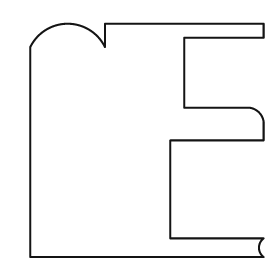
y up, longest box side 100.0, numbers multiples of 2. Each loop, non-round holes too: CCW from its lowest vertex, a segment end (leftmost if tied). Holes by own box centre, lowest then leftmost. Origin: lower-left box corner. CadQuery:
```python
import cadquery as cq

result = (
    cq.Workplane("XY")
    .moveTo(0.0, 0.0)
    .lineTo(100.0, 0.0)
    .threePointArc((98.0, 4.0), (100.0, 8.0))
    .lineTo(60.0, 8.0)
    .lineTo(60.0, 50.0)
    .lineTo(100.0, 50.0)
    .lineTo(100.0, 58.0)
    .threePointArc((98.0, 62.0), (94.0, 64.0))
    .lineTo(66.0, 64.0)
    .lineTo(66.0, 94.0)
    .lineTo(100.0, 94.0)
    .lineTo(100.0, 100.0)
    .lineTo(32.0, 100.0)
    .lineTo(32.0, 90.0)
    .threePointArc((16.0, 100.0), (0.0, 90.0))
    .close()
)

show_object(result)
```